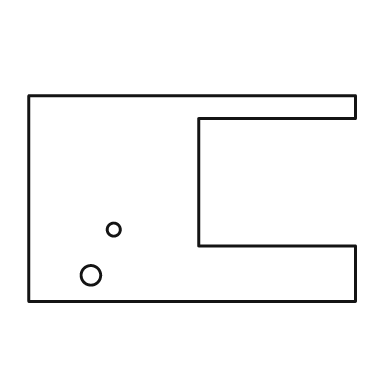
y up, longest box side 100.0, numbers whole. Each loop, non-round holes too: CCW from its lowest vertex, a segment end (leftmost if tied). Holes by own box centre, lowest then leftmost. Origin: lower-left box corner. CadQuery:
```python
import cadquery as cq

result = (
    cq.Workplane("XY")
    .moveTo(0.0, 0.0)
    .lineTo(100.0, 0.0)
    .lineTo(100.0, 17.0)
    .lineTo(52.0, 17.0)
    .lineTo(52.0, 56.0)
    .lineTo(100.0, 56.0)
    .lineTo(100.0, 63.0)
    .lineTo(0.0, 63.0)
    .close()
    .moveTo(19.0, 8.0)
    .circle(3.0)
    .moveTo(26.0, 22.0)
    .circle(2.0)
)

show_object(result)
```